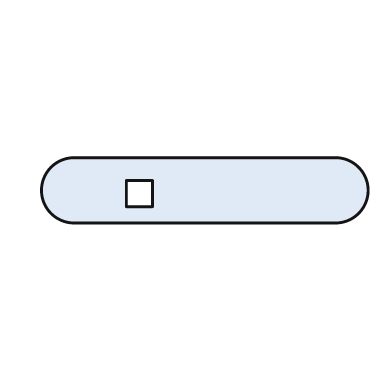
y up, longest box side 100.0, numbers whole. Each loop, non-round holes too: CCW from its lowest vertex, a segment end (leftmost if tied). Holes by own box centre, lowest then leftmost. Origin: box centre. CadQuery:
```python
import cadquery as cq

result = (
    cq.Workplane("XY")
    .moveTo(-40.0, -10.0)
    .lineTo(40.0, -10.0)
    .threePointArc((50.0, 0.0), (40.0, 10.0))
    .lineTo(-40.0, 10.0)
    .threePointArc((-50.0, 0.0), (-40.0, -10.0))
    .close()
    .moveTo(-24.0, -5.0)
    .lineTo(-16.0, -5.0)
    .lineTo(-16.0, 3.0)
    .lineTo(-24.0, 3.0)
    .close()
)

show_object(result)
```